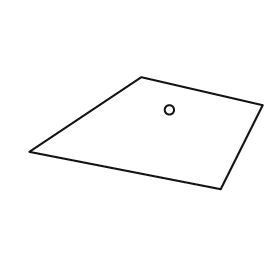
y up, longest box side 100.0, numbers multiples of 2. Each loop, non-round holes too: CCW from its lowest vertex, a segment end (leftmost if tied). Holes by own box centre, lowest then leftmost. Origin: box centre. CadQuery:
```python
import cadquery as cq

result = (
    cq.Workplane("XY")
    .moveTo(32.0, -24.0)
    .lineTo(50.0, 12.0)
    .lineTo(-2.0, 24.0)
    .lineTo(-50.0, -8.0)
    .close()
    .moveTo(10.0, 10.0)
    .circle(2.0)
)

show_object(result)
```